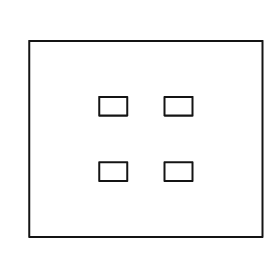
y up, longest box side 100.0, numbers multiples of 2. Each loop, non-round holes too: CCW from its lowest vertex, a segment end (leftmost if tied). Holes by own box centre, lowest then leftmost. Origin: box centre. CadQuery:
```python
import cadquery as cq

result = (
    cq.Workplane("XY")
    .moveTo(-50.0, -42.0)
    .lineTo(50.0, -42.0)
    .lineTo(50.0, 42.0)
    .lineTo(-50.0, 42.0)
    .close()
    .moveTo(-20.0, -18.0)
    .lineTo(-8.0, -18.0)
    .lineTo(-8.0, -10.0)
    .lineTo(-20.0, -10.0)
    .close()
    .moveTo(8.0, -18.0)
    .lineTo(20.0, -18.0)
    .lineTo(20.0, -10.0)
    .lineTo(8.0, -10.0)
    .close()
    .moveTo(-20.0, 10.0)
    .lineTo(-8.0, 10.0)
    .lineTo(-8.0, 18.0)
    .lineTo(-20.0, 18.0)
    .close()
    .moveTo(8.0, 10.0)
    .lineTo(20.0, 10.0)
    .lineTo(20.0, 18.0)
    .lineTo(8.0, 18.0)
    .close()
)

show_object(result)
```